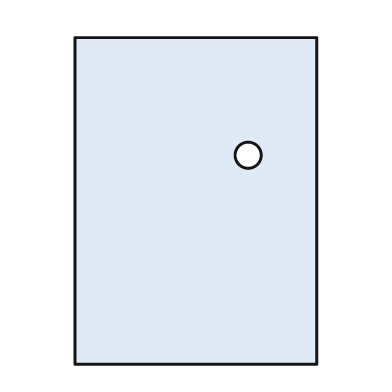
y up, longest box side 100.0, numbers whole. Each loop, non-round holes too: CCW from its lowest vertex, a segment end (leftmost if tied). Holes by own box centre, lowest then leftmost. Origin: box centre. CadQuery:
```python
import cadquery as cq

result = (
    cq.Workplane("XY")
    .moveTo(-37.0, -50.0)
    .lineTo(37.0, -50.0)
    .lineTo(37.0, 50.0)
    .lineTo(-37.0, 50.0)
    .close()
    .moveTo(16.0, 14.0)
    .circle(4.0)
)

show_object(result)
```